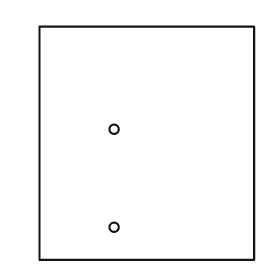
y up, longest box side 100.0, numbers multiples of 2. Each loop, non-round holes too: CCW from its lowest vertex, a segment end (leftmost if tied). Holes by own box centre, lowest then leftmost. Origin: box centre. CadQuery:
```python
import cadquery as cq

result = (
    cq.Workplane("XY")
    .moveTo(-46.0, -50.0)
    .lineTo(46.0, -50.0)
    .lineTo(46.0, 50.0)
    .lineTo(-46.0, 50.0)
    .close()
    .moveTo(-14.0, -36.0)
    .circle(2.0)
    .moveTo(-14.0, 6.0)
    .circle(2.0)
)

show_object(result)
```